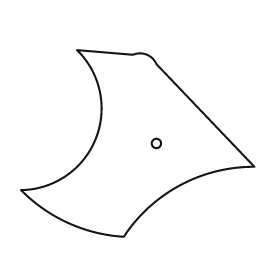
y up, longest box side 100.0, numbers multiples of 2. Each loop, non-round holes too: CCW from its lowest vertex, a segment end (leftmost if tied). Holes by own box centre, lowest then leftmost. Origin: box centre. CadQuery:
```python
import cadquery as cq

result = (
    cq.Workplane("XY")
    .moveTo(-6.0, -40.0)
    .threePointArc((18.0, -18.0), (50.0, -10.0))
    .lineTo(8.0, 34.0)
    .threePointArc((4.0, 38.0), (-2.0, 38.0))
    .lineTo(-26.0, 40.0)
    .threePointArc((-18.0, 2.0), (-50.0, -20.0))
    .threePointArc((-30.0, -34.0), (-6.0, -40.0))
    .close()
    .moveTo(8.0, 0.0)
    .circle(2.0)
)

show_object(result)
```